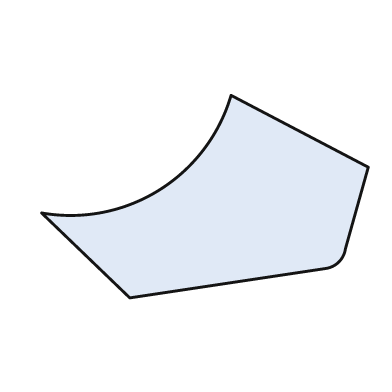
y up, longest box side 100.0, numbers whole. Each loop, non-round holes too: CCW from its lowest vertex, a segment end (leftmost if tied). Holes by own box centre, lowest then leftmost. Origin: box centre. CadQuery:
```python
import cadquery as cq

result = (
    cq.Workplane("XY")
    .moveTo(-23.0, -31.0)
    .lineTo(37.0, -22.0)
    .threePointArc((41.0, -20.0), (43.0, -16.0))
    .lineTo(50.0, 9.0)
    .lineTo(8.0, 31.0)
    .threePointArc((-14.0, 2.0), (-50.0, -5.0))
    .close()
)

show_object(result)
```